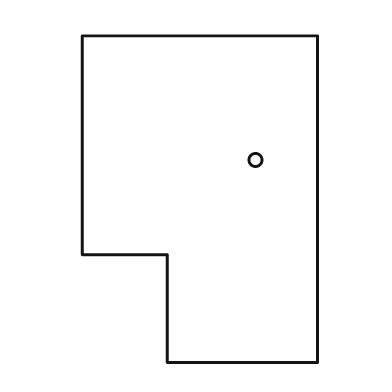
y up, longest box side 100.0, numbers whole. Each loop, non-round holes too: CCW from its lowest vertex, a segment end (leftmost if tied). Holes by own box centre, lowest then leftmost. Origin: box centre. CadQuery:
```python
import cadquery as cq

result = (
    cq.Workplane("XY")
    .moveTo(-10.0, -50.0)
    .lineTo(36.0, -50.0)
    .lineTo(36.0, 50.0)
    .lineTo(-36.0, 50.0)
    .lineTo(-36.0, -17.0)
    .lineTo(-10.0, -17.0)
    .close()
    .moveTo(17.0, 12.0)
    .circle(2.0)
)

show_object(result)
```